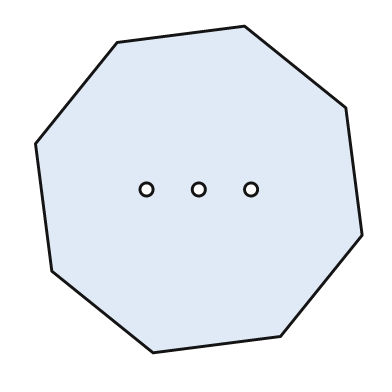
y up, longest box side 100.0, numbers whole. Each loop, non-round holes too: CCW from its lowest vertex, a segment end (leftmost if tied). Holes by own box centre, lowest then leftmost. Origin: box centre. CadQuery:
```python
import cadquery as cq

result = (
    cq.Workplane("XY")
    .moveTo(-14.0, -50.0)
    .lineTo(25.0, -45.0)
    .lineTo(50.0, -14.0)
    .lineTo(45.0, 25.0)
    .lineTo(14.0, 50.0)
    .lineTo(-25.0, 45.0)
    .lineTo(-50.0, 14.0)
    .lineTo(-45.0, -25.0)
    .close()
    .moveTo(-16.0, 0.0)
    .circle(2.0)
    .moveTo(0.0, 0.0)
    .circle(2.0)
    .moveTo(16.0, 0.0)
    .circle(2.0)
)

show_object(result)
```